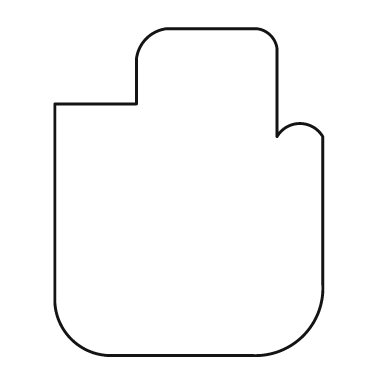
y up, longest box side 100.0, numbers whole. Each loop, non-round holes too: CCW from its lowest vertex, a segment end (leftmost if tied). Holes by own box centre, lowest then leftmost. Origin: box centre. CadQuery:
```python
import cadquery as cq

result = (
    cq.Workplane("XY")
    .moveTo(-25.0, -50.0)
    .lineTo(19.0, -50.0)
    .threePointArc((35.0, -44.0), (41.0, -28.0))
    .lineTo(41.0, 17.0)
    .threePointArc((34.0, 21.0), (27.0, 17.0))
    .lineTo(27.0, 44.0)
    .threePointArc((25.0, 48.0), (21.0, 50.0))
    .lineTo(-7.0, 50.0)
    .threePointArc((-13.0, 47.0), (-16.0, 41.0))
    .lineTo(-16.0, 27.0)
    .lineTo(-41.0, 27.0)
    .lineTo(-41.0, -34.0)
    .threePointArc((-36.0, -45.0), (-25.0, -50.0))
    .close()
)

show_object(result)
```